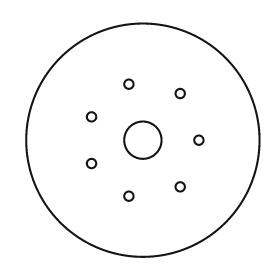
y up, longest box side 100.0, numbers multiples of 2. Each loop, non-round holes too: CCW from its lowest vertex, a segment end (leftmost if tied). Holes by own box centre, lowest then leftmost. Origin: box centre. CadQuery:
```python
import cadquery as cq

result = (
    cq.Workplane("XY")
    .moveTo(0.0, 0.0)
    .circle(50.0)
    .moveTo(-6.0, -24.0)
    .circle(2.0)
    .moveTo(16.0, -20.0)
    .circle(2.0)
    .moveTo(-22.0, -10.0)
    .circle(2.0)
    .moveTo(0.0, 0.0)
    .circle(8.0)
    .moveTo(24.0, 0.0)
    .circle(2.0)
    .moveTo(-22.0, 10.0)
    .circle(2.0)
    .moveTo(16.0, 20.0)
    .circle(2.0)
    .moveTo(-6.0, 24.0)
    .circle(2.0)
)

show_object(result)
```